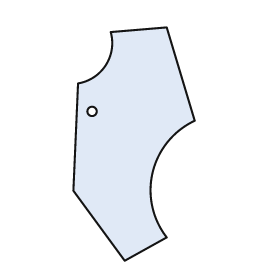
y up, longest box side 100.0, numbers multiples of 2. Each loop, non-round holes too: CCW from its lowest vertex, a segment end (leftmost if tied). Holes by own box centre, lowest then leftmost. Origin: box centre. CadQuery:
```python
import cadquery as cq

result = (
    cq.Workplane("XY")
    .moveTo(-4.0, -50.0)
    .lineTo(14.0, -40.0)
    .threePointArc((8.0, -12.0), (26.0, 10.0))
    .lineTo(14.0, 50.0)
    .lineTo(-10.0, 48.0)
    .threePointArc((-12.0, 34.0), (-24.0, 26.0))
    .lineTo(-26.0, -20.0)
    .close()
    .moveTo(-18.0, 14.0)
    .circle(2.0)
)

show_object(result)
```